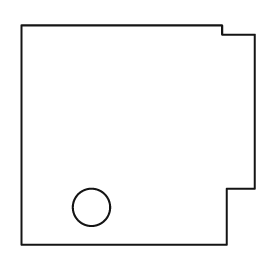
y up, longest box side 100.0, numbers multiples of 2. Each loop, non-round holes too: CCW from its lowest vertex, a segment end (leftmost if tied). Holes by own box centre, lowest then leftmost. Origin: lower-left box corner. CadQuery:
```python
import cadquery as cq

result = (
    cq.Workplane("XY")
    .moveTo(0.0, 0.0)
    .lineTo(88.0, 0.0)
    .lineTo(88.0, 24.0)
    .lineTo(100.0, 24.0)
    .lineTo(100.0, 90.0)
    .lineTo(86.0, 90.0)
    .lineTo(86.0, 94.0)
    .lineTo(0.0, 94.0)
    .close()
    .moveTo(30.0, 16.0)
    .circle(8.0)
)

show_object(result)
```